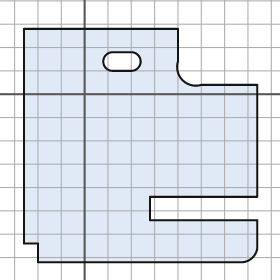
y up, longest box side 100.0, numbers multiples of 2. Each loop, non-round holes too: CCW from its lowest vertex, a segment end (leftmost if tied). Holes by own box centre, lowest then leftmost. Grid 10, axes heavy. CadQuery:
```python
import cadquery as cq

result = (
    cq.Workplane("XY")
    .moveTo(-20.0, -72.0)
    .lineTo(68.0, -72.0)
    .threePointArc((72.0, -70.0), (74.0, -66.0))
    .lineTo(74.0, -54.0)
    .lineTo(28.0, -54.0)
    .lineTo(28.0, -44.0)
    .lineTo(74.0, -44.0)
    .lineTo(74.0, 4.0)
    .lineTo(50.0, 4.0)
    .threePointArc((42.0, 6.0), (40.0, 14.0))
    .lineTo(40.0, 28.0)
    .lineTo(-26.0, 28.0)
    .lineTo(-26.0, -64.0)
    .lineTo(-20.0, -64.0)
    .close()
    .moveTo(12.0, 10.0)
    .lineTo(20.0, 10.0)
    .threePointArc((24.0, 14.0), (20.0, 18.0))
    .lineTo(12.0, 18.0)
    .threePointArc((8.0, 14.0), (12.0, 10.0))
    .close()
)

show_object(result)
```